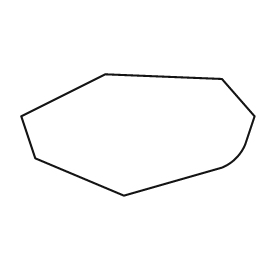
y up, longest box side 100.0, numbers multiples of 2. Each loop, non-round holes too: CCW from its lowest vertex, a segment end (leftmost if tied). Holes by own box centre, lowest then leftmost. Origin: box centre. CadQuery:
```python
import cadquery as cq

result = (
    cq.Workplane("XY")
    .moveTo(-6.0, -26.0)
    .lineTo(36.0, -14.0)
    .threePointArc((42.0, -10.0), (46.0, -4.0))
    .lineTo(50.0, 8.0)
    .lineTo(36.0, 24.0)
    .lineTo(-14.0, 26.0)
    .lineTo(-50.0, 8.0)
    .lineTo(-44.0, -10.0)
    .close()
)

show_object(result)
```